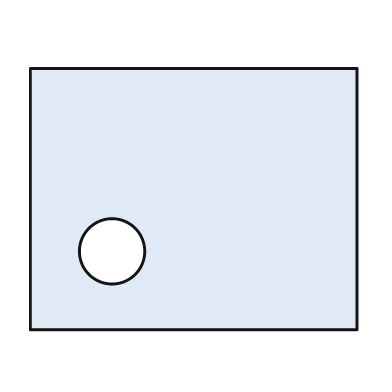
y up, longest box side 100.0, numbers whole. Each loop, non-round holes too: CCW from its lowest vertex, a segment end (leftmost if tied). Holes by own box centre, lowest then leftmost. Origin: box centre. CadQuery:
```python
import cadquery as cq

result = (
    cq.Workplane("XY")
    .moveTo(-50.0, -40.0)
    .lineTo(50.0, -40.0)
    .lineTo(50.0, 40.0)
    .lineTo(-50.0, 40.0)
    .close()
    .moveTo(-25.0, -16.0)
    .circle(10.0)
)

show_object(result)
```